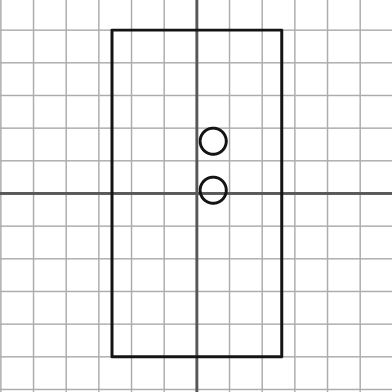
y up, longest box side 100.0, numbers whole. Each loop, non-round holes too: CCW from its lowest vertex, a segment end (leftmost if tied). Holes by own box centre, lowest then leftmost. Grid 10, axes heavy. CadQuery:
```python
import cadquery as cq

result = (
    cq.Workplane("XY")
    .moveTo(-26.0, -50.0)
    .lineTo(26.0, -50.0)
    .lineTo(26.0, 50.0)
    .lineTo(-26.0, 50.0)
    .close()
    .moveTo(5.0, 1.0)
    .circle(4.0)
    .moveTo(5.0, 16.0)
    .circle(4.0)
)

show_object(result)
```